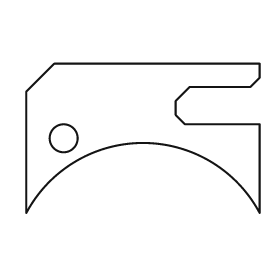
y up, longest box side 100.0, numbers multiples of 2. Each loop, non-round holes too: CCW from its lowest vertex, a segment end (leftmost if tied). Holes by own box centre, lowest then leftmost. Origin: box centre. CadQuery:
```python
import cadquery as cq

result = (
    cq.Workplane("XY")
    .moveTo(-50.0, -32.0)
    .threePointArc((0.0, -2.0), (50.0, -32.0))
    .lineTo(50.0, 6.0)
    .lineTo(18.0, 6.0)
    .lineTo(14.0, 10.0)
    .lineTo(14.0, 16.0)
    .lineTo(20.0, 22.0)
    .lineTo(46.0, 22.0)
    .lineTo(50.0, 26.0)
    .lineTo(50.0, 32.0)
    .lineTo(-38.0, 32.0)
    .lineTo(-50.0, 20.0)
    .close()
    .moveTo(-34.0, 0.0)
    .circle(6.0)
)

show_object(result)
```